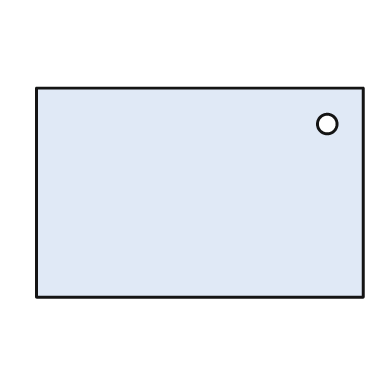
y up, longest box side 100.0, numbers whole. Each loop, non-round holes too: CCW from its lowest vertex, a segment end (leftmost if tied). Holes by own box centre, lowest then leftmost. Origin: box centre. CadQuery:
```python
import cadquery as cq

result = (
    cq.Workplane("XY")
    .moveTo(-50.0, -32.0)
    .lineTo(50.0, -32.0)
    .lineTo(50.0, 32.0)
    .lineTo(-50.0, 32.0)
    .close()
    .moveTo(39.0, 21.0)
    .circle(3.0)
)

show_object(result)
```